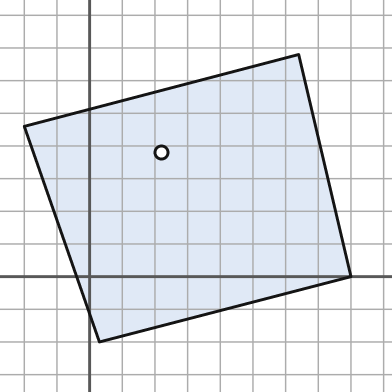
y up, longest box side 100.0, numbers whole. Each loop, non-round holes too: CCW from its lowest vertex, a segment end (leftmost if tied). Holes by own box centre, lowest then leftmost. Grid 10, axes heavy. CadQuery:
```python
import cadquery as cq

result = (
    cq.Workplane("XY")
    .moveTo(3.0, -20.0)
    .lineTo(80.0, 0.0)
    .lineTo(64.0, 68.0)
    .lineTo(-20.0, 46.0)
    .close()
    .moveTo(22.0, 38.0)
    .circle(2.0)
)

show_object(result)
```